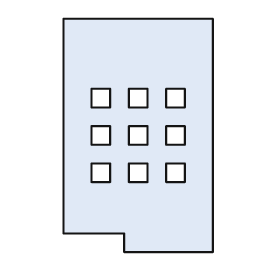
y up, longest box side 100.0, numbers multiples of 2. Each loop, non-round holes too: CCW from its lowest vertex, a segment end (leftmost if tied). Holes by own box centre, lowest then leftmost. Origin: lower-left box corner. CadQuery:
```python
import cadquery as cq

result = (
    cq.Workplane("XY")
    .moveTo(26.0, 0.0)
    .lineTo(64.0, 0.0)
    .lineTo(64.0, 100.0)
    .lineTo(0.0, 100.0)
    .lineTo(0.0, 8.0)
    .lineTo(26.0, 8.0)
    .close()
    .moveTo(12.0, 30.0)
    .lineTo(20.0, 30.0)
    .lineTo(20.0, 38.0)
    .lineTo(12.0, 38.0)
    .close()
    .moveTo(28.0, 30.0)
    .lineTo(36.0, 30.0)
    .lineTo(36.0, 38.0)
    .lineTo(28.0, 38.0)
    .close()
    .moveTo(44.0, 30.0)
    .lineTo(52.0, 30.0)
    .lineTo(52.0, 38.0)
    .lineTo(44.0, 38.0)
    .close()
    .moveTo(12.0, 46.0)
    .lineTo(20.0, 46.0)
    .lineTo(20.0, 54.0)
    .lineTo(12.0, 54.0)
    .close()
    .moveTo(28.0, 46.0)
    .lineTo(36.0, 46.0)
    .lineTo(36.0, 54.0)
    .lineTo(28.0, 54.0)
    .close()
    .moveTo(44.0, 46.0)
    .lineTo(52.0, 46.0)
    .lineTo(52.0, 54.0)
    .lineTo(44.0, 54.0)
    .close()
    .moveTo(12.0, 62.0)
    .lineTo(20.0, 62.0)
    .lineTo(20.0, 70.0)
    .lineTo(12.0, 70.0)
    .close()
    .moveTo(28.0, 62.0)
    .lineTo(36.0, 62.0)
    .lineTo(36.0, 70.0)
    .lineTo(28.0, 70.0)
    .close()
    .moveTo(44.0, 62.0)
    .lineTo(52.0, 62.0)
    .lineTo(52.0, 70.0)
    .lineTo(44.0, 70.0)
    .close()
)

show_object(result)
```